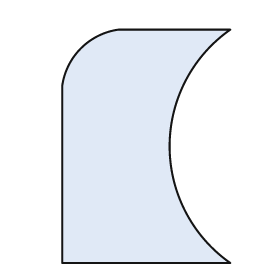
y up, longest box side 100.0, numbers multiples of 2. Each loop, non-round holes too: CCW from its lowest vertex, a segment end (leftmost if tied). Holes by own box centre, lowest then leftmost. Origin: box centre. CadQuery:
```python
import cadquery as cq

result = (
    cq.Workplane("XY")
    .moveTo(-36.0, -50.0)
    .lineTo(36.0, -50.0)
    .threePointArc((10.0, 0.0), (36.0, 50.0))
    .lineTo(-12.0, 50.0)
    .threePointArc((-28.0, 42.0), (-36.0, 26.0))
    .close()
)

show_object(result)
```